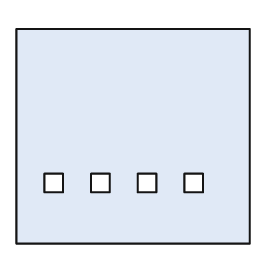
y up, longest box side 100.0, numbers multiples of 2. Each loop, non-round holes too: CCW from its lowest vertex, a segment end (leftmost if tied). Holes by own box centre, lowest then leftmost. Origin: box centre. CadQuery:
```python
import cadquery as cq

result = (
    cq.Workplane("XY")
    .moveTo(-50.0, -46.0)
    .lineTo(50.0, -46.0)
    .lineTo(50.0, 46.0)
    .lineTo(-50.0, 46.0)
    .close()
    .moveTo(-38.0, -24.0)
    .lineTo(-30.0, -24.0)
    .lineTo(-30.0, -16.0)
    .lineTo(-38.0, -16.0)
    .close()
    .moveTo(-18.0, -24.0)
    .lineTo(-10.0, -24.0)
    .lineTo(-10.0, -16.0)
    .lineTo(-18.0, -16.0)
    .close()
    .moveTo(2.0, -24.0)
    .lineTo(10.0, -24.0)
    .lineTo(10.0, -16.0)
    .lineTo(2.0, -16.0)
    .close()
    .moveTo(22.0, -24.0)
    .lineTo(30.0, -24.0)
    .lineTo(30.0, -16.0)
    .lineTo(22.0, -16.0)
    .close()
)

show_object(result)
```